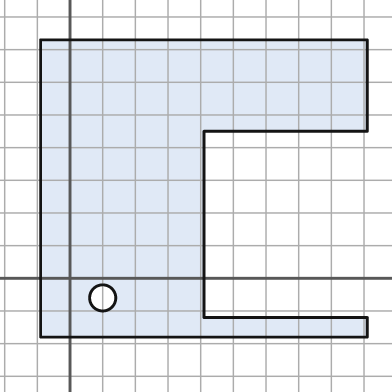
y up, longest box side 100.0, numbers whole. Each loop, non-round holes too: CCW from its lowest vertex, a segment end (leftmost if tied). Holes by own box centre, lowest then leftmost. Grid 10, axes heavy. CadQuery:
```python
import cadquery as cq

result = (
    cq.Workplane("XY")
    .moveTo(-9.0, -18.0)
    .lineTo(91.0, -18.0)
    .lineTo(91.0, -12.0)
    .lineTo(41.0, -12.0)
    .lineTo(41.0, 45.0)
    .lineTo(91.0, 45.0)
    .lineTo(91.0, 73.0)
    .lineTo(-9.0, 73.0)
    .close()
    .moveTo(10.0, -6.0)
    .circle(4.0)
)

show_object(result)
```